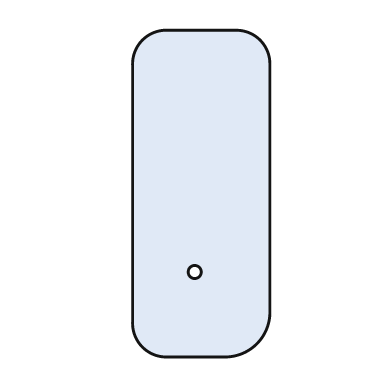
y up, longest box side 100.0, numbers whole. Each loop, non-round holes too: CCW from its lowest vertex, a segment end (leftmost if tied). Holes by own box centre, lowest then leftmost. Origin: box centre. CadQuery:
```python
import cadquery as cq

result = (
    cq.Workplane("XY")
    .moveTo(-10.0, -50.0)
    .lineTo(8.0, -50.0)
    .threePointArc((17.0, -46.0), (21.0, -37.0))
    .lineTo(21.0, 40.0)
    .threePointArc((18.0, 47.0), (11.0, 50.0))
    .lineTo(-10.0, 50.0)
    .threePointArc((-18.0, 47.0), (-21.0, 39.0))
    .lineTo(-21.0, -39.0)
    .threePointArc((-18.0, -47.0), (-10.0, -50.0))
    .close()
    .moveTo(-2.0, -24.0)
    .circle(2.0)
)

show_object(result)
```